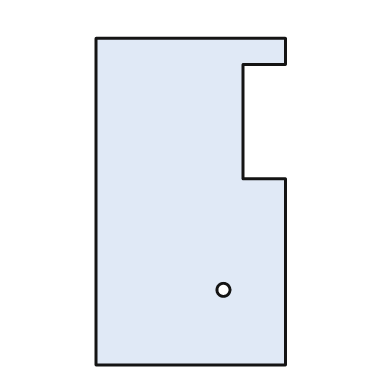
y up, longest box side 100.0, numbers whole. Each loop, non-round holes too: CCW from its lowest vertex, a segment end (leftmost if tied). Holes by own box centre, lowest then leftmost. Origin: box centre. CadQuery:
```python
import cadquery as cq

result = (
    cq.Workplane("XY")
    .moveTo(-29.0, -50.0)
    .lineTo(29.0, -50.0)
    .lineTo(29.0, 7.0)
    .lineTo(16.0, 7.0)
    .lineTo(16.0, 42.0)
    .lineTo(29.0, 42.0)
    .lineTo(29.0, 50.0)
    .lineTo(-29.0, 50.0)
    .close()
    .moveTo(10.0, -27.0)
    .circle(2.0)
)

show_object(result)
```